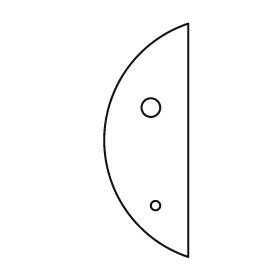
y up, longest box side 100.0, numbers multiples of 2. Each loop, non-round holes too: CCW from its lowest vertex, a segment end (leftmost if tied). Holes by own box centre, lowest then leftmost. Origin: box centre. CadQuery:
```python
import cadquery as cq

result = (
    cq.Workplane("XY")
    .moveTo(18.0, -50.0)
    .lineTo(18.0, 50.0)
    .threePointArc((-18.0, 0.0), (18.0, -50.0))
    .close()
    .moveTo(4.0, -28.0)
    .circle(2.0)
    .moveTo(2.0, 14.0)
    .circle(4.0)
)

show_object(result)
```